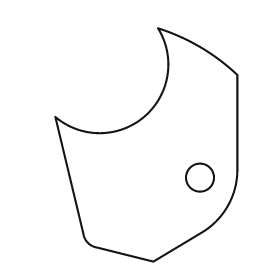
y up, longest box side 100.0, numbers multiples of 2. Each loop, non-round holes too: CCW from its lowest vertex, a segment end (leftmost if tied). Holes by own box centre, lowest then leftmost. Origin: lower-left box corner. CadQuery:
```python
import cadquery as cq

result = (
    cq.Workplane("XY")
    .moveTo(42.0, 0.0)
    .lineTo(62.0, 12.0)
    .threePointArc((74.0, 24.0), (78.0, 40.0))
    .lineTo(78.0, 80.0)
    .threePointArc((62.0, 92.0), (44.0, 100.0))
    .threePointArc((38.0, 62.0), (0.0, 62.0))
    .lineTo(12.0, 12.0)
    .threePointArc((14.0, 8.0), (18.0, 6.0))
    .close()
    .moveTo(62.0, 36.0)
    .circle(6.0)
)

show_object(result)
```